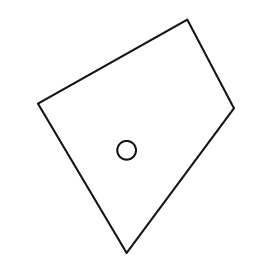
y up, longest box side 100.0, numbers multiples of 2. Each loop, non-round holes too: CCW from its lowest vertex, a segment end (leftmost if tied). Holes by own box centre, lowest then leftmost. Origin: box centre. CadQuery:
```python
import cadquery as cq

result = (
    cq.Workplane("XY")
    .moveTo(-4.0, -50.0)
    .lineTo(42.0, 12.0)
    .lineTo(22.0, 50.0)
    .lineTo(-42.0, 14.0)
    .close()
    .moveTo(-4.0, -6.0)
    .circle(4.0)
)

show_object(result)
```